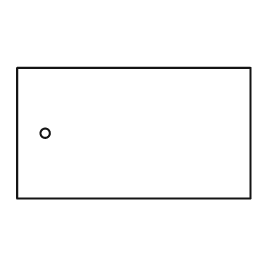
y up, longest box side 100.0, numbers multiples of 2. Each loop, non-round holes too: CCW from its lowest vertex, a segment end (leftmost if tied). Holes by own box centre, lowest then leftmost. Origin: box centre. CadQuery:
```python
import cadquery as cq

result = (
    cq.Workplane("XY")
    .moveTo(-50.0, -28.0)
    .lineTo(50.0, -28.0)
    .lineTo(50.0, 28.0)
    .lineTo(-50.0, 28.0)
    .close()
    .moveTo(-38.0, 0.0)
    .circle(2.0)
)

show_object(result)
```